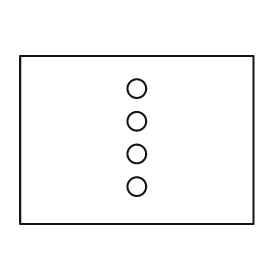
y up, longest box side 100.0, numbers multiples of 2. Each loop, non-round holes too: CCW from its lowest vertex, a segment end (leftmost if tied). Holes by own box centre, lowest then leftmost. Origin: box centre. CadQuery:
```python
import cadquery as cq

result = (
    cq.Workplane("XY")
    .moveTo(-50.0, -36.0)
    .lineTo(50.0, -36.0)
    .lineTo(50.0, 36.0)
    .lineTo(-50.0, 36.0)
    .close()
    .moveTo(0.0, -20.0)
    .circle(4.0)
    .moveTo(0.0, -6.0)
    .circle(4.0)
    .moveTo(0.0, 8.0)
    .circle(4.0)
    .moveTo(0.0, 22.0)
    .circle(4.0)
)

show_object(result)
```